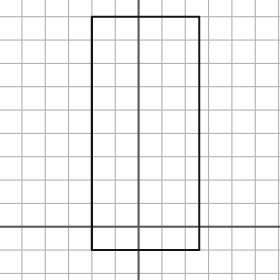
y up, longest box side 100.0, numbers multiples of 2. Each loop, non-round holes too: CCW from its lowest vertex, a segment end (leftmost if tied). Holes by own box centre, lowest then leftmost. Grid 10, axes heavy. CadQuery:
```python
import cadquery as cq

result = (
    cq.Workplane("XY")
    .moveTo(-20.0, -10.0)
    .lineTo(26.0, -10.0)
    .lineTo(26.0, 90.0)
    .lineTo(-20.0, 90.0)
    .close()
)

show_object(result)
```